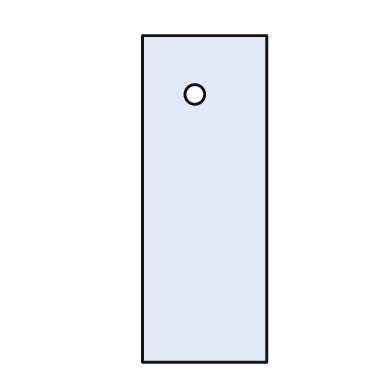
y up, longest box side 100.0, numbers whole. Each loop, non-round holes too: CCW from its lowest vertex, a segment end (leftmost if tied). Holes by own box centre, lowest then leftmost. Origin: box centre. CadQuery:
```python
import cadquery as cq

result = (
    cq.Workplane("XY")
    .moveTo(-19.0, -50.0)
    .lineTo(19.0, -50.0)
    .lineTo(19.0, 50.0)
    .lineTo(-19.0, 50.0)
    .close()
    .moveTo(-3.0, 32.0)
    .circle(3.0)
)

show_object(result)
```